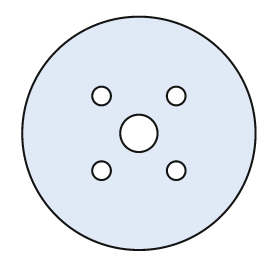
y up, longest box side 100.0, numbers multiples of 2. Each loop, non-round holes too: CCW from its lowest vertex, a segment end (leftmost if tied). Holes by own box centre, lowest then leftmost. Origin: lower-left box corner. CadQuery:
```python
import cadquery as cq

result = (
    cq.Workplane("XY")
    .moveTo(50.0, 50.0)
    .circle(50.0)
    .moveTo(34.0, 34.0)
    .circle(4.0)
    .moveTo(66.0, 34.0)
    .circle(4.0)
    .moveTo(50.0, 50.0)
    .circle(8.0)
    .moveTo(34.0, 66.0)
    .circle(4.0)
    .moveTo(66.0, 66.0)
    .circle(4.0)
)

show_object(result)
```